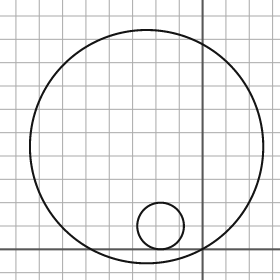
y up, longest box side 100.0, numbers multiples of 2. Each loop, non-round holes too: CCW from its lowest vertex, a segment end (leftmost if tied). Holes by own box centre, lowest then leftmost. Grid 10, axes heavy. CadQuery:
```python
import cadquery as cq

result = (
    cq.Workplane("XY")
    .moveTo(-24.0, 44.0)
    .circle(50.0)
    .moveTo(-18.0, 10.0)
    .circle(10.0)
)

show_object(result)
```